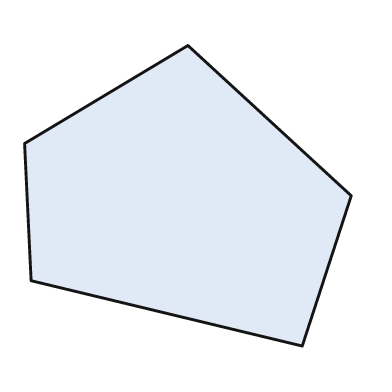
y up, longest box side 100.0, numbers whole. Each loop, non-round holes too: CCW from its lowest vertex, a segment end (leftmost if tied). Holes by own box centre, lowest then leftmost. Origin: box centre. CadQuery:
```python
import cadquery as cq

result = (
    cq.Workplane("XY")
    .moveTo(35.0, -46.0)
    .lineTo(50.0, 0.0)
    .lineTo(0.0, 46.0)
    .lineTo(-50.0, 16.0)
    .lineTo(-48.0, -26.0)
    .close()
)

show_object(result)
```